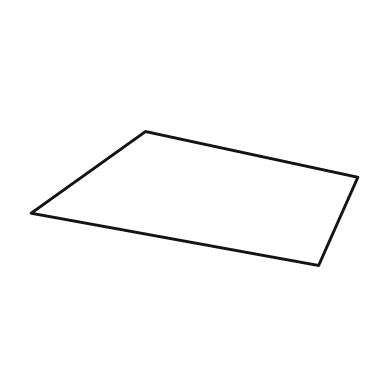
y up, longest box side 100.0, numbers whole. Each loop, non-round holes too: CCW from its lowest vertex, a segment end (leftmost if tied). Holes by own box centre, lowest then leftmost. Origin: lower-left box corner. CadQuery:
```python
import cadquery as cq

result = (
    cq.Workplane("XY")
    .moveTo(88.0, 0.0)
    .lineTo(100.0, 27.0)
    .lineTo(35.0, 41.0)
    .lineTo(0.0, 16.0)
    .close()
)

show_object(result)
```